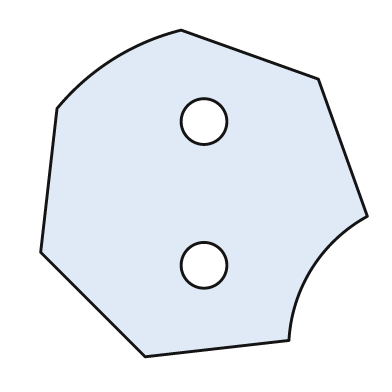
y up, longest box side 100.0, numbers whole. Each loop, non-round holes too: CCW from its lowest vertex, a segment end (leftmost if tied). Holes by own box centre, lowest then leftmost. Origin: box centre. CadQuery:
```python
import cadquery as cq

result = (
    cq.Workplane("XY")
    .moveTo(-18.0, -50.0)
    .lineTo(26.0, -45.0)
    .threePointArc((33.0, -23.0), (50.0, -7.0))
    .lineTo(35.0, 35.0)
    .lineTo(-7.0, 50.0)
    .threePointArc((-28.0, 41.0), (-45.0, 26.0))
    .lineTo(-50.0, -18.0)
    .close()
    .moveTo(0.0, -22.0)
    .circle(7.0)
    .moveTo(0.0, 22.0)
    .circle(7.0)
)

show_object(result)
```